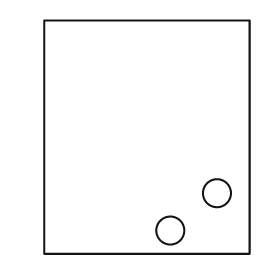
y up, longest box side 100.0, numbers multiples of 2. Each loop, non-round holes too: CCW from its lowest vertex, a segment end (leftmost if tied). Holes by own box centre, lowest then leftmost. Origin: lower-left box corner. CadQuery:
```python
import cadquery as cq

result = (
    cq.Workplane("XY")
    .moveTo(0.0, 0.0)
    .lineTo(88.0, 0.0)
    .lineTo(88.0, 100.0)
    .lineTo(0.0, 100.0)
    .close()
    .moveTo(54.0, 10.0)
    .circle(6.0)
    .moveTo(74.0, 26.0)
    .circle(6.0)
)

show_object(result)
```